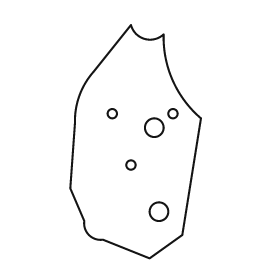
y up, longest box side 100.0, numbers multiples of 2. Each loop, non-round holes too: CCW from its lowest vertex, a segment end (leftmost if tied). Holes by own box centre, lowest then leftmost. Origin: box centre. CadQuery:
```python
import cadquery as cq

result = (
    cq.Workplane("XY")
    .moveTo(6.0, -50.0)
    .lineTo(20.0, -40.0)
    .lineTo(28.0, 10.0)
    .threePointArc((16.0, 26.0), (12.0, 46.0))
    .threePointArc((4.0, 44.0), (-2.0, 50.0))
    .lineTo(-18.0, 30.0)
    .threePointArc((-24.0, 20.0), (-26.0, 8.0))
    .lineTo(-28.0, -20.0)
    .lineTo(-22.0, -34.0)
    .threePointArc((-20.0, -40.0), (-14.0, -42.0))
    .close()
    .moveTo(10.0, -30.0)
    .circle(4.0)
    .moveTo(-2.0, -10.0)
    .circle(2.0)
    .moveTo(8.0, 6.0)
    .circle(4.0)
    .moveTo(-10.0, 12.0)
    .circle(2.0)
    .moveTo(16.0, 12.0)
    .circle(2.0)
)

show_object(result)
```